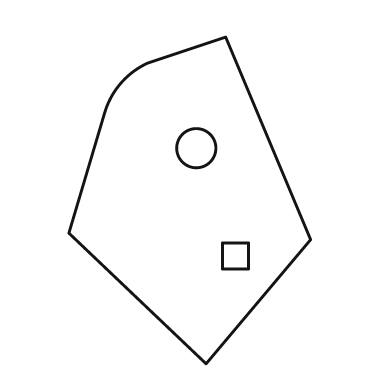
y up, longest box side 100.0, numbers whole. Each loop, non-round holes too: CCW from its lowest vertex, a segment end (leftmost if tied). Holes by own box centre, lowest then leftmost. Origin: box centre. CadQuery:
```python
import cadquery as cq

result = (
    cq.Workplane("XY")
    .moveTo(5.0, -50.0)
    .lineTo(37.0, -12.0)
    .lineTo(11.0, 50.0)
    .lineTo(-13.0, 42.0)
    .threePointArc((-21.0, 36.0), (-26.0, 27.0))
    .lineTo(-37.0, -10.0)
    .close()
    .moveTo(10.0, -21.0)
    .lineTo(18.0, -21.0)
    .lineTo(18.0, -13.0)
    .lineTo(10.0, -13.0)
    .close()
    .moveTo(2.0, 16.0)
    .circle(6.0)
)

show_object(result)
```